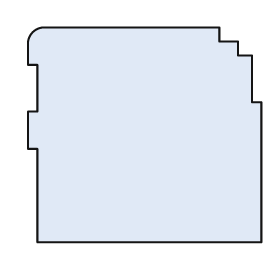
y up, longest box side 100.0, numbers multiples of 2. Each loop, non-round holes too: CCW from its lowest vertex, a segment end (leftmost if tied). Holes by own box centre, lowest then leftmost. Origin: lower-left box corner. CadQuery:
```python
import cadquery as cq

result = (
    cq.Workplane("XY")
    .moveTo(4.0, 0.0)
    .lineTo(100.0, 0.0)
    .lineTo(100.0, 60.0)
    .lineTo(96.0, 60.0)
    .lineTo(96.0, 80.0)
    .lineTo(90.0, 80.0)
    .lineTo(90.0, 86.0)
    .lineTo(82.0, 86.0)
    .lineTo(82.0, 92.0)
    .lineTo(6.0, 92.0)
    .threePointArc((2.0, 90.0), (0.0, 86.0))
    .lineTo(0.0, 76.0)
    .lineTo(4.0, 76.0)
    .lineTo(4.0, 56.0)
    .lineTo(0.0, 56.0)
    .lineTo(0.0, 40.0)
    .lineTo(4.0, 40.0)
    .close()
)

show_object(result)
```